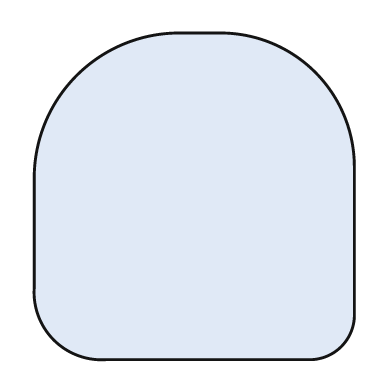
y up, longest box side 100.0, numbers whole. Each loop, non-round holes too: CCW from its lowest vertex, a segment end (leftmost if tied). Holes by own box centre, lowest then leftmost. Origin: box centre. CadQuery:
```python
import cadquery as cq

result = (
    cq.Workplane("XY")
    .moveTo(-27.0, -50.0)
    .lineTo(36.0, -50.0)
    .threePointArc((45.0, -46.0), (49.0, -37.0))
    .lineTo(49.0, 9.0)
    .threePointArc((37.0, 38.0), (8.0, 50.0))
    .lineTo(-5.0, 50.0)
    .threePointArc((-36.0, 37.0), (-49.0, 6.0))
    .lineTo(-49.0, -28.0)
    .threePointArc((-43.0, -44.0), (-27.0, -50.0))
    .close()
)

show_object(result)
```